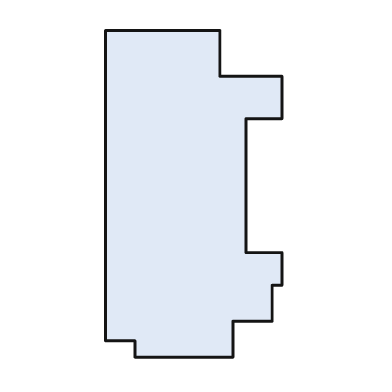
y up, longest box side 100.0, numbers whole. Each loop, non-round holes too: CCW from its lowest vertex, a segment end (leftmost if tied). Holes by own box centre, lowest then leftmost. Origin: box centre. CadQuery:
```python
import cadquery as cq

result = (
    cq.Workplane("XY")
    .moveTo(-18.0, -50.0)
    .lineTo(12.0, -50.0)
    .lineTo(12.0, -39.0)
    .lineTo(24.0, -39.0)
    .lineTo(24.0, -28.0)
    .lineTo(27.0, -28.0)
    .lineTo(27.0, -18.0)
    .lineTo(16.0, -18.0)
    .lineTo(16.0, 23.0)
    .lineTo(27.0, 23.0)
    .lineTo(27.0, 36.0)
    .lineTo(8.0, 36.0)
    .lineTo(8.0, 50.0)
    .lineTo(-27.0, 50.0)
    .lineTo(-27.0, -45.0)
    .lineTo(-18.0, -45.0)
    .close()
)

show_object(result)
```